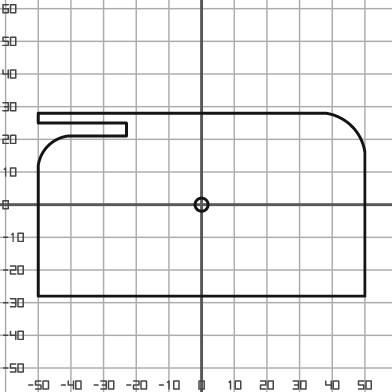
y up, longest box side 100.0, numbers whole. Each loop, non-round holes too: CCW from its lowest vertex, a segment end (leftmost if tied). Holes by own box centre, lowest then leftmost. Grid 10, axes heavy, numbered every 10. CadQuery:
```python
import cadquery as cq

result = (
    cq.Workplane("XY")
    .moveTo(-50.0, -28.0)
    .lineTo(50.0, -28.0)
    .lineTo(50.0, 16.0)
    .threePointArc((46.0, 24.0), (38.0, 28.0))
    .lineTo(-50.0, 28.0)
    .lineTo(-50.0, 25.0)
    .lineTo(-23.0, 25.0)
    .lineTo(-23.0, 21.0)
    .lineTo(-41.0, 21.0)
    .threePointArc((-47.0, 18.0), (-50.0, 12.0))
    .close()
    .moveTo(0.0, 0.0)
    .circle(2.0)
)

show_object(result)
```